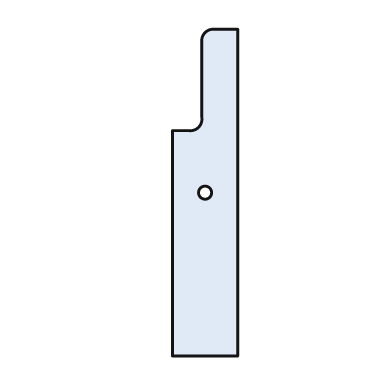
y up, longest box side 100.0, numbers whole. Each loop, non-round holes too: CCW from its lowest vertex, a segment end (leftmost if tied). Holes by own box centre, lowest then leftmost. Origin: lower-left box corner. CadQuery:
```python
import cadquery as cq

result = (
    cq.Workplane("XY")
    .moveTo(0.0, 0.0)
    .lineTo(20.0, 0.0)
    .lineTo(20.0, 100.0)
    .lineTo(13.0, 100.0)
    .threePointArc((10.0, 99.0), (9.0, 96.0))
    .lineTo(9.0, 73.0)
    .threePointArc((8.0, 70.0), (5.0, 69.0))
    .lineTo(0.0, 69.0)
    .close()
    .moveTo(10.0, 50.0)
    .circle(2.0)
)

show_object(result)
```